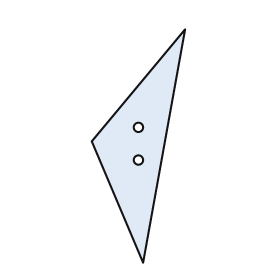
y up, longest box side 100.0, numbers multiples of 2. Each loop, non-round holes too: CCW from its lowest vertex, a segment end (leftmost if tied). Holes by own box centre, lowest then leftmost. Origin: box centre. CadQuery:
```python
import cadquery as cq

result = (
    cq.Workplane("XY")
    .moveTo(2.0, -50.0)
    .lineTo(20.0, 50.0)
    .lineTo(-20.0, 2.0)
    .close()
    .moveTo(0.0, -6.0)
    .circle(2.0)
    .moveTo(0.0, 8.0)
    .circle(2.0)
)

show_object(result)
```